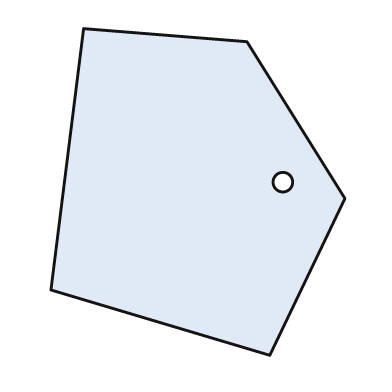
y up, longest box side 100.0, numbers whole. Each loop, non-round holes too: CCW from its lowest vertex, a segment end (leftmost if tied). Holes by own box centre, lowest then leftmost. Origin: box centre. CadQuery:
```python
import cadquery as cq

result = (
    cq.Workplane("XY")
    .moveTo(22.0, -50.0)
    .lineTo(45.0, -2.0)
    .lineTo(15.0, 46.0)
    .lineTo(-35.0, 50.0)
    .lineTo(-45.0, -30.0)
    .close()
    .moveTo(26.0, 3.0)
    .circle(3.0)
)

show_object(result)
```